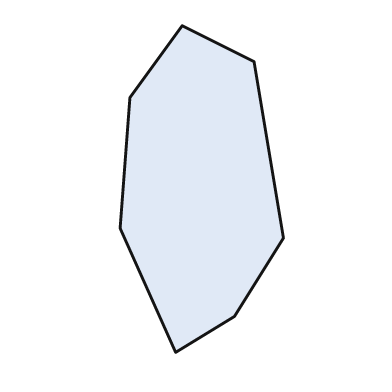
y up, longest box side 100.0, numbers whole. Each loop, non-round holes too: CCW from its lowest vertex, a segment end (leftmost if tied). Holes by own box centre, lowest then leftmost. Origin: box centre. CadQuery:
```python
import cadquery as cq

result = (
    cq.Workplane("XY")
    .moveTo(-8.0, -50.0)
    .lineTo(10.0, -39.0)
    .lineTo(25.0, -15.0)
    .lineTo(16.0, 39.0)
    .lineTo(-6.0, 50.0)
    .lineTo(-22.0, 28.0)
    .lineTo(-25.0, -12.0)
    .close()
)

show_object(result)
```